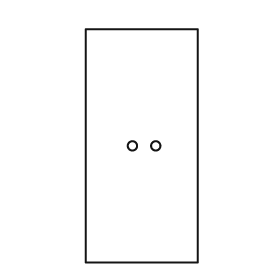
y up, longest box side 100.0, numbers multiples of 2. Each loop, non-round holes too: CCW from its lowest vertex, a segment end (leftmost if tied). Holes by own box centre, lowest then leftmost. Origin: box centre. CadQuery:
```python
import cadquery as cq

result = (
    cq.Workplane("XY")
    .moveTo(-24.0, -50.0)
    .lineTo(24.0, -50.0)
    .lineTo(24.0, 50.0)
    .lineTo(-24.0, 50.0)
    .close()
    .moveTo(-4.0, 0.0)
    .circle(2.0)
    .moveTo(6.0, 0.0)
    .circle(2.0)
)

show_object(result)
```